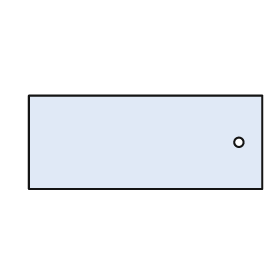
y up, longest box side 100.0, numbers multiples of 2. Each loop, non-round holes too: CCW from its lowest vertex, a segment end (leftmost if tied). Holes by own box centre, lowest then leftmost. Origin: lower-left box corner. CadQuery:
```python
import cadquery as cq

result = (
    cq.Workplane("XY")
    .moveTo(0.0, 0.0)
    .lineTo(100.0, 0.0)
    .lineTo(100.0, 40.0)
    .lineTo(0.0, 40.0)
    .close()
    .moveTo(90.0, 20.0)
    .circle(2.0)
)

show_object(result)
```